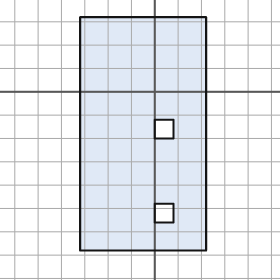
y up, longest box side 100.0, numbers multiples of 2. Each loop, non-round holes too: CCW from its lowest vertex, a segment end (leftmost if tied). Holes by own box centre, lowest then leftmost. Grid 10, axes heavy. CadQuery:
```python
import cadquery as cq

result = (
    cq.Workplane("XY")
    .moveTo(-32.0, -68.0)
    .lineTo(22.0, -68.0)
    .lineTo(22.0, 32.0)
    .lineTo(-32.0, 32.0)
    .close()
    .moveTo(0.0, -56.0)
    .lineTo(8.0, -56.0)
    .lineTo(8.0, -48.0)
    .lineTo(0.0, -48.0)
    .close()
    .moveTo(0.0, -20.0)
    .lineTo(8.0, -20.0)
    .lineTo(8.0, -12.0)
    .lineTo(0.0, -12.0)
    .close()
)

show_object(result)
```